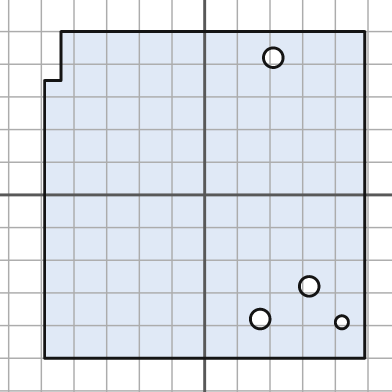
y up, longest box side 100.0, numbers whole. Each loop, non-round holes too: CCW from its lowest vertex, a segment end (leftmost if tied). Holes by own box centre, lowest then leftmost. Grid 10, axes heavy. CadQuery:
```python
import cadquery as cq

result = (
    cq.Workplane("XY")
    .moveTo(-49.0, -50.0)
    .lineTo(49.0, -50.0)
    .lineTo(49.0, 50.0)
    .lineTo(-44.0, 50.0)
    .lineTo(-44.0, 35.0)
    .lineTo(-49.0, 35.0)
    .close()
    .moveTo(42.0, -39.0)
    .circle(2.0)
    .moveTo(17.0, -38.0)
    .circle(3.0)
    .moveTo(32.0, -28.0)
    .circle(3.0)
    .moveTo(21.0, 42.0)
    .circle(3.0)
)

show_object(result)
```